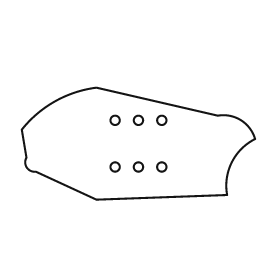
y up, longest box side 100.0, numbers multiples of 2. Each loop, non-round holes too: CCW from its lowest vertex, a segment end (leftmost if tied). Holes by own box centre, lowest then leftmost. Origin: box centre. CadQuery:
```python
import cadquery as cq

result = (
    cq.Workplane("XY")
    .moveTo(-18.0, -24.0)
    .lineTo(38.0, -22.0)
    .threePointArc((40.0, -8.0), (50.0, 2.0))
    .threePointArc((44.0, 10.0), (34.0, 12.0))
    .lineTo(-18.0, 24.0)
    .threePointArc((-36.0, 18.0), (-50.0, 6.0))
    .lineTo(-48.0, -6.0)
    .threePointArc((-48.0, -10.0), (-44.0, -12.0))
    .close()
    .moveTo(-10.0, -10.0)
    .circle(2.0)
    .moveTo(0.0, -10.0)
    .circle(2.0)
    .moveTo(10.0, -10.0)
    .circle(2.0)
    .moveTo(-10.0, 10.0)
    .circle(2.0)
    .moveTo(0.0, 10.0)
    .circle(2.0)
    .moveTo(10.0, 10.0)
    .circle(2.0)
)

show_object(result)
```